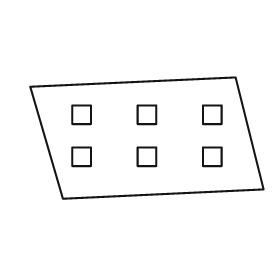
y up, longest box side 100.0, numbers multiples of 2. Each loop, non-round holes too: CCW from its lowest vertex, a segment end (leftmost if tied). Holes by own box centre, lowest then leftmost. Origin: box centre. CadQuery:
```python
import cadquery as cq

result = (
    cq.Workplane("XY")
    .moveTo(-36.0, -26.0)
    .lineTo(50.0, -22.0)
    .lineTo(38.0, 26.0)
    .lineTo(-50.0, 22.0)
    .close()
    .moveTo(-32.0, -12.0)
    .lineTo(-24.0, -12.0)
    .lineTo(-24.0, -4.0)
    .lineTo(-32.0, -4.0)
    .close()
    .moveTo(-4.0, -12.0)
    .lineTo(4.0, -12.0)
    .lineTo(4.0, -4.0)
    .lineTo(-4.0, -4.0)
    .close()
    .moveTo(24.0, -12.0)
    .lineTo(32.0, -12.0)
    .lineTo(32.0, -4.0)
    .lineTo(24.0, -4.0)
    .close()
    .moveTo(-32.0, 6.0)
    .lineTo(-24.0, 6.0)
    .lineTo(-24.0, 14.0)
    .lineTo(-32.0, 14.0)
    .close()
    .moveTo(-4.0, 6.0)
    .lineTo(4.0, 6.0)
    .lineTo(4.0, 14.0)
    .lineTo(-4.0, 14.0)
    .close()
    .moveTo(24.0, 6.0)
    .lineTo(32.0, 6.0)
    .lineTo(32.0, 14.0)
    .lineTo(24.0, 14.0)
    .close()
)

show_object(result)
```